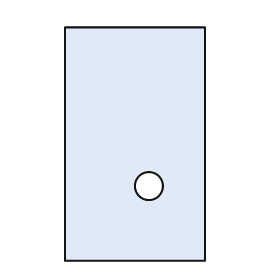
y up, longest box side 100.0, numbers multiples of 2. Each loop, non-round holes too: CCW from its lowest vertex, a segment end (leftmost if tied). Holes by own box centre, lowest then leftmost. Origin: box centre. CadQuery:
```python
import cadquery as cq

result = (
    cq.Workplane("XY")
    .moveTo(-30.0, -50.0)
    .lineTo(30.0, -50.0)
    .lineTo(30.0, 50.0)
    .lineTo(-30.0, 50.0)
    .close()
    .moveTo(6.0, -18.0)
    .circle(6.0)
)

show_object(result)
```